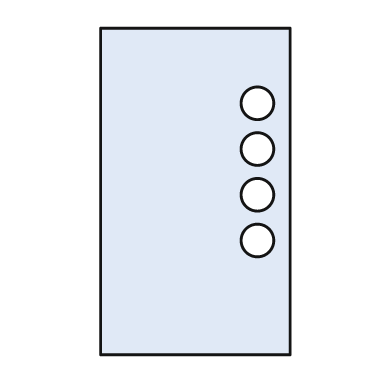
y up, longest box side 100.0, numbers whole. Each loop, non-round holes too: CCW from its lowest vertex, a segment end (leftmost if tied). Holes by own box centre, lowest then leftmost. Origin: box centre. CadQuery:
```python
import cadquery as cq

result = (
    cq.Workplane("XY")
    .moveTo(-29.0, -50.0)
    .lineTo(29.0, -50.0)
    .lineTo(29.0, 50.0)
    .lineTo(-29.0, 50.0)
    .close()
    .moveTo(19.0, -15.0)
    .circle(5.0)
    .moveTo(19.0, -1.0)
    .circle(5.0)
    .moveTo(19.0, 13.0)
    .circle(5.0)
    .moveTo(19.0, 27.0)
    .circle(5.0)
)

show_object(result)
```